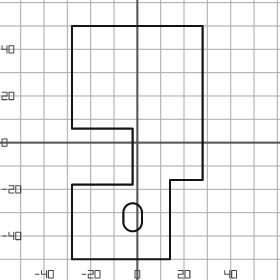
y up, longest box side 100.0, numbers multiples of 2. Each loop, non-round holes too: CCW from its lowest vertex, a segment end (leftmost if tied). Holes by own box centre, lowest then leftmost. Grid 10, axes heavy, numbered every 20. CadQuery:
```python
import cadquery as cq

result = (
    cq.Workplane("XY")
    .moveTo(-28.0, -50.0)
    .lineTo(14.0, -50.0)
    .lineTo(14.0, -16.0)
    .lineTo(28.0, -16.0)
    .lineTo(28.0, 50.0)
    .lineTo(-28.0, 50.0)
    .lineTo(-28.0, 6.0)
    .lineTo(-2.0, 6.0)
    .lineTo(-2.0, -18.0)
    .lineTo(-28.0, -18.0)
    .close()
    .moveTo(-6.0, -34.0)
    .threePointArc((-2.0, -38.0), (2.0, -34.0))
    .lineTo(2.0, -30.0)
    .threePointArc((-2.0, -26.0), (-6.0, -30.0))
    .close()
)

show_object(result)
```